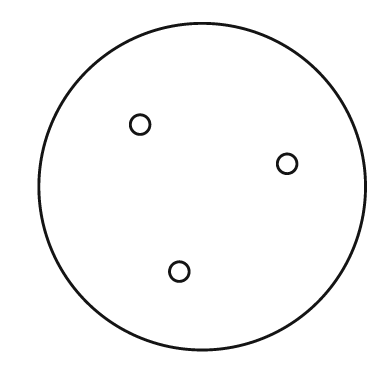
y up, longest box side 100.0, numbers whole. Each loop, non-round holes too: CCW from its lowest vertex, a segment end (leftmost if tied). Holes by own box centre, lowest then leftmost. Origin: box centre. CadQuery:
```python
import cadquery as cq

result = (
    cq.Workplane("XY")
    .moveTo(0.0, 0.0)
    .circle(50.0)
    .moveTo(-7.0, -26.0)
    .circle(3.0)
    .moveTo(26.0, 7.0)
    .circle(3.0)
    .moveTo(-19.0, 19.0)
    .circle(3.0)
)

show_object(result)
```